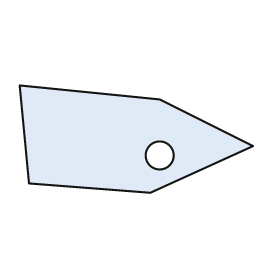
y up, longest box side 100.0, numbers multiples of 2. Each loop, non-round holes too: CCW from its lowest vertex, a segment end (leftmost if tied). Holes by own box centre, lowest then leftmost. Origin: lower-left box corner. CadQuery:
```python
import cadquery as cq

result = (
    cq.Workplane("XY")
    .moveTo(56.0, 0.0)
    .lineTo(100.0, 20.0)
    .lineTo(60.0, 40.0)
    .lineTo(0.0, 46.0)
    .lineTo(4.0, 4.0)
    .close()
    .moveTo(60.0, 16.0)
    .circle(6.0)
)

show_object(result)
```